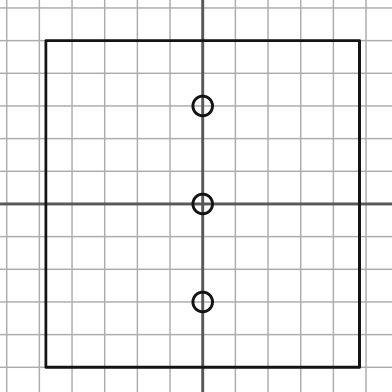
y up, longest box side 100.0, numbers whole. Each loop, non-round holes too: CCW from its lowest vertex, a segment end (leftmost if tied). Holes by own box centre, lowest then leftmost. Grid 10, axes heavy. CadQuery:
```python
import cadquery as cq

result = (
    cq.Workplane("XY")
    .moveTo(-48.0, -50.0)
    .lineTo(48.0, -50.0)
    .lineTo(48.0, 50.0)
    .lineTo(-48.0, 50.0)
    .close()
    .moveTo(0.0, -30.0)
    .circle(3.0)
    .moveTo(0.0, 0.0)
    .circle(3.0)
    .moveTo(0.0, 30.0)
    .circle(3.0)
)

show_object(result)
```